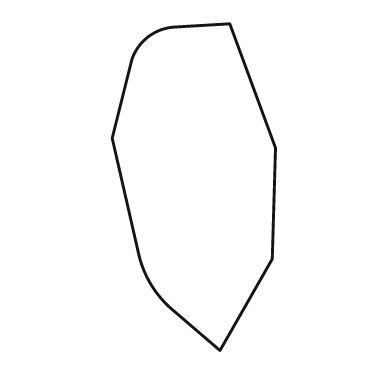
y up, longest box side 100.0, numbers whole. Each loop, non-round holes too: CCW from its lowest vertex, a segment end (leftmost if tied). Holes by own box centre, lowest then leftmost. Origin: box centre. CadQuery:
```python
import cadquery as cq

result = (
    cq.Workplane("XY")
    .moveTo(8.0, -50.0)
    .lineTo(24.0, -22.0)
    .lineTo(25.0, 12.0)
    .lineTo(11.0, 50.0)
    .lineTo(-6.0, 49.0)
    .threePointArc((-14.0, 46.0), (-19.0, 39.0))
    .lineTo(-25.0, 15.0)
    .lineTo(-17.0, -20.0)
    .threePointArc((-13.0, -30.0), (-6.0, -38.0))
    .close()
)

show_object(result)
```